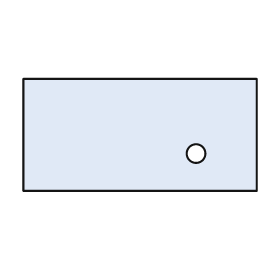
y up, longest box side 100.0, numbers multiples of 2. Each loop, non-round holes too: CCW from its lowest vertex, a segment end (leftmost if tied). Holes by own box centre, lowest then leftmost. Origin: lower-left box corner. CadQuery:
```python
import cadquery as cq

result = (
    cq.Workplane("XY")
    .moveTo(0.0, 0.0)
    .lineTo(100.0, 0.0)
    .lineTo(100.0, 48.0)
    .lineTo(0.0, 48.0)
    .close()
    .moveTo(74.0, 16.0)
    .circle(4.0)
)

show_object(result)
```